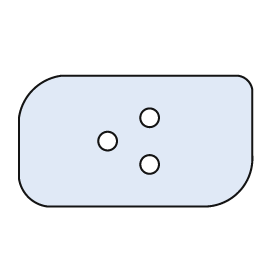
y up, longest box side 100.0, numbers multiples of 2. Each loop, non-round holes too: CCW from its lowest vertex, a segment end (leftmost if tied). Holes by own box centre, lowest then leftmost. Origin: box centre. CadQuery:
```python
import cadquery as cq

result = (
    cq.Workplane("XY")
    .moveTo(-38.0, -28.0)
    .lineTo(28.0, -28.0)
    .threePointArc((44.0, -22.0), (50.0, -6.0))
    .lineTo(50.0, 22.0)
    .threePointArc((48.0, 26.0), (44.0, 28.0))
    .lineTo(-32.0, 28.0)
    .threePointArc((-44.0, 22.0), (-50.0, 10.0))
    .lineTo(-50.0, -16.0)
    .threePointArc((-46.0, -24.0), (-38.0, -28.0))
    .close()
    .moveTo(6.0, -10.0)
    .circle(4.0)
    .moveTo(-12.0, 0.0)
    .circle(4.0)
    .moveTo(6.0, 10.0)
    .circle(4.0)
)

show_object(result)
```